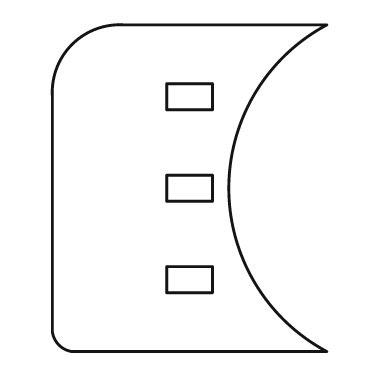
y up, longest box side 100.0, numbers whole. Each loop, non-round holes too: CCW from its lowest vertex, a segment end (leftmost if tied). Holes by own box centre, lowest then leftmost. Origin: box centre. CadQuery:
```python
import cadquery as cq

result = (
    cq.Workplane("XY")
    .moveTo(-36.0, -50.0)
    .lineTo(42.0, -50.0)
    .threePointArc((12.0, 0.0), (42.0, 50.0))
    .lineTo(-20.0, 50.0)
    .threePointArc((-36.0, 44.0), (-42.0, 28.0))
    .lineTo(-42.0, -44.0)
    .threePointArc((-40.0, -48.0), (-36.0, -50.0))
    .close()
    .moveTo(-7.0, -32.0)
    .lineTo(7.0, -32.0)
    .lineTo(7.0, -24.0)
    .lineTo(-7.0, -24.0)
    .close()
    .moveTo(-7.0, -4.0)
    .lineTo(7.0, -4.0)
    .lineTo(7.0, 4.0)
    .lineTo(-7.0, 4.0)
    .close()
    .moveTo(-7.0, 24.0)
    .lineTo(7.0, 24.0)
    .lineTo(7.0, 32.0)
    .lineTo(-7.0, 32.0)
    .close()
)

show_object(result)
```